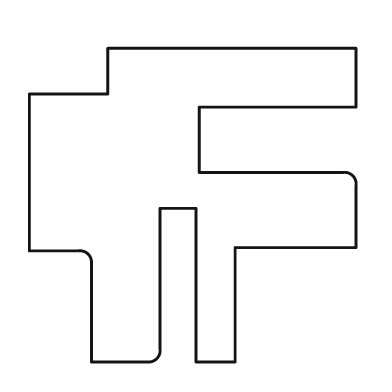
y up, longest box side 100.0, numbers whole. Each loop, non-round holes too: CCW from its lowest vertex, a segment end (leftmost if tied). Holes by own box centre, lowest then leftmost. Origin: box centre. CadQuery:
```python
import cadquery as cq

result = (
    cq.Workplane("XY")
    .moveTo(-31.0, -48.0)
    .lineTo(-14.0, -48.0)
    .threePointArc((-11.0, -47.0), (-10.0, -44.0))
    .lineTo(-10.0, -1.0)
    .lineTo(1.0, -1.0)
    .lineTo(1.0, -48.0)
    .lineTo(13.0, -48.0)
    .lineTo(13.0, -13.0)
    .lineTo(50.0, -13.0)
    .lineTo(50.0, 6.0)
    .threePointArc((49.0, 9.0), (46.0, 10.0))
    .lineTo(2.0, 10.0)
    .lineTo(2.0, 30.0)
    .lineTo(50.0, 30.0)
    .lineTo(50.0, 48.0)
    .lineTo(-26.0, 48.0)
    .lineTo(-26.0, 34.0)
    .lineTo(-50.0, 34.0)
    .lineTo(-50.0, -14.0)
    .lineTo(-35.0, -14.0)
    .threePointArc((-32.0, -15.0), (-31.0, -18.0))
    .close()
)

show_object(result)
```